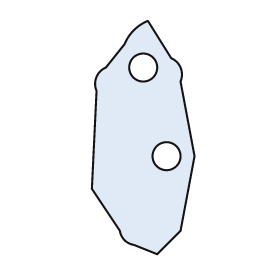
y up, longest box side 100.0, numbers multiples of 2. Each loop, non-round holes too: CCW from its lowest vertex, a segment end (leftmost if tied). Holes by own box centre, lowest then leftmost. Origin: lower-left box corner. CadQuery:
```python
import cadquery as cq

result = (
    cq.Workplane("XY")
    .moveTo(28.0, 0.0)
    .lineTo(38.0, 10.0)
    .lineTo(44.0, 42.0)
    .lineTo(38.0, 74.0)
    .threePointArc((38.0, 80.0), (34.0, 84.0))
    .lineTo(24.0, 100.0)
    .threePointArc((18.0, 96.0), (14.0, 90.0))
    .lineTo(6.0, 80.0)
    .threePointArc((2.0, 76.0), (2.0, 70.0))
    .lineTo(0.0, 28.0)
    .lineTo(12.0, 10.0)
    .threePointArc((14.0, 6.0), (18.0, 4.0))
    .close()
    .moveTo(32.0, 42.0)
    .circle(6.0)
    .moveTo(22.0, 80.0)
    .circle(6.0)
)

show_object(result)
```